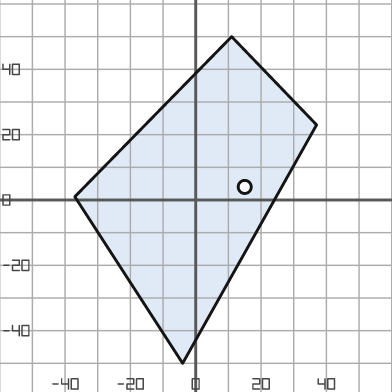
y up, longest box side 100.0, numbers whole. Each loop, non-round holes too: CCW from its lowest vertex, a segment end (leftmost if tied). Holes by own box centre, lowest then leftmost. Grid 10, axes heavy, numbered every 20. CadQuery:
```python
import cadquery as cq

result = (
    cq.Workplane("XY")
    .moveTo(-4.0, -50.0)
    .lineTo(37.0, 23.0)
    .lineTo(11.0, 50.0)
    .lineTo(-37.0, 1.0)
    .close()
    .moveTo(15.0, 4.0)
    .circle(2.0)
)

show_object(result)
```